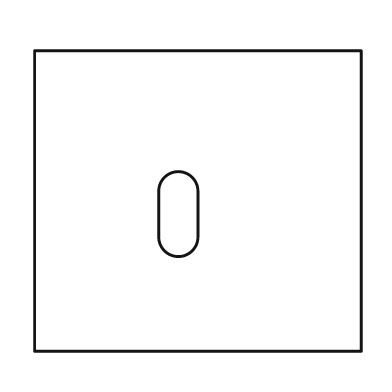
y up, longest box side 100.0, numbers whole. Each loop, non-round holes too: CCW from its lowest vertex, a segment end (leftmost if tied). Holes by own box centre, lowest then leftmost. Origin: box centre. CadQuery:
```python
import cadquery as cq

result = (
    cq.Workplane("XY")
    .moveTo(-50.0, -46.0)
    .lineTo(50.0, -46.0)
    .lineTo(50.0, 46.0)
    .lineTo(-50.0, 46.0)
    .close()
    .moveTo(-12.0, -11.0)
    .threePointArc((-6.0, -17.0), (0.0, -11.0))
    .lineTo(0.0, 3.0)
    .threePointArc((-6.0, 9.0), (-12.0, 3.0))
    .close()
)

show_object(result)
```